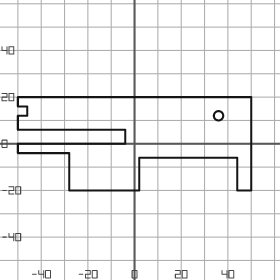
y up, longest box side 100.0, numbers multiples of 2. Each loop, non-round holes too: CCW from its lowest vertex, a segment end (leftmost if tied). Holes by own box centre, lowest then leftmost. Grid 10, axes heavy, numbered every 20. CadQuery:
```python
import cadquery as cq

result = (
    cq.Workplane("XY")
    .moveTo(-28.0, -20.0)
    .lineTo(2.0, -20.0)
    .lineTo(2.0, -6.0)
    .lineTo(44.0, -6.0)
    .lineTo(44.0, -20.0)
    .lineTo(50.0, -20.0)
    .lineTo(50.0, 20.0)
    .lineTo(-50.0, 20.0)
    .lineTo(-50.0, 16.0)
    .lineTo(-46.0, 16.0)
    .lineTo(-46.0, 12.0)
    .lineTo(-50.0, 12.0)
    .lineTo(-50.0, 6.0)
    .lineTo(-4.0, 6.0)
    .lineTo(-4.0, 0.0)
    .lineTo(-50.0, 0.0)
    .lineTo(-50.0, -4.0)
    .lineTo(-28.0, -4.0)
    .close()
    .moveTo(36.0, 12.0)
    .circle(2.0)
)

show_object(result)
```